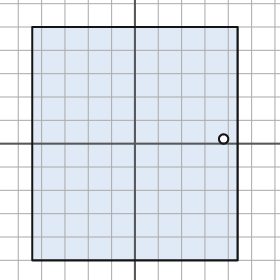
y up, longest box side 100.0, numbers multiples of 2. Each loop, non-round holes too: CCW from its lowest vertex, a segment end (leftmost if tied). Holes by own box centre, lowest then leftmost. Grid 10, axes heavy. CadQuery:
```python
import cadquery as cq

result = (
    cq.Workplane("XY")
    .moveTo(-44.0, -50.0)
    .lineTo(44.0, -50.0)
    .lineTo(44.0, 50.0)
    .lineTo(-44.0, 50.0)
    .close()
    .moveTo(38.0, 2.0)
    .circle(2.0)
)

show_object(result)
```